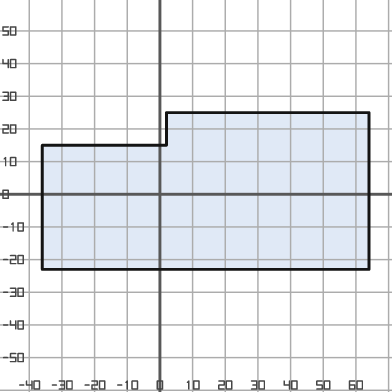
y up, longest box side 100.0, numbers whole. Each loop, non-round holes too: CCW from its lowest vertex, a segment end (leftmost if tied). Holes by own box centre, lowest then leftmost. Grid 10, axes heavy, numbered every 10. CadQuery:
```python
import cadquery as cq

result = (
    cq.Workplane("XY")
    .moveTo(-36.0, -23.0)
    .lineTo(64.0, -23.0)
    .lineTo(64.0, 25.0)
    .lineTo(2.0, 25.0)
    .lineTo(2.0, 15.0)
    .lineTo(-36.0, 15.0)
    .close()
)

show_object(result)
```